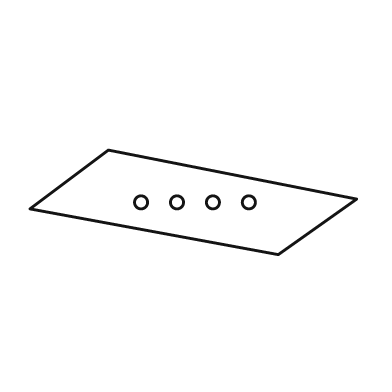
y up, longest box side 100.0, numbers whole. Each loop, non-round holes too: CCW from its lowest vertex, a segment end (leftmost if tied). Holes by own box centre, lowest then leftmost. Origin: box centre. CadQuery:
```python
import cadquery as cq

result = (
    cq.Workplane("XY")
    .moveTo(26.0, -16.0)
    .lineTo(50.0, 1.0)
    .lineTo(-26.0, 16.0)
    .lineTo(-50.0, -2.0)
    .close()
    .moveTo(-16.0, 0.0)
    .circle(2.0)
    .moveTo(-5.0, 0.0)
    .circle(2.0)
    .moveTo(6.0, 0.0)
    .circle(2.0)
    .moveTo(17.0, 0.0)
    .circle(2.0)
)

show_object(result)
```